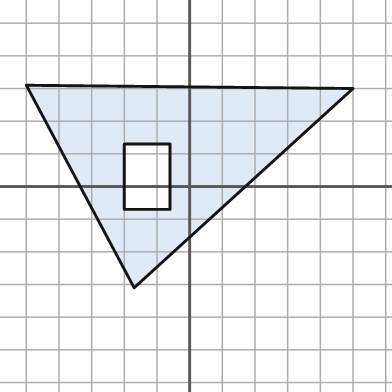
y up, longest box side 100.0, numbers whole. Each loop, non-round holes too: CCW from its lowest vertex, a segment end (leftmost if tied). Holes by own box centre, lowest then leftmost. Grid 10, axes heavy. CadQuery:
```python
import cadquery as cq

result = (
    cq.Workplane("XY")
    .moveTo(-17.0, -31.0)
    .lineTo(50.0, 30.0)
    .lineTo(-50.0, 31.0)
    .close()
    .moveTo(-20.0, -7.0)
    .lineTo(-6.0, -7.0)
    .lineTo(-6.0, 13.0)
    .lineTo(-20.0, 13.0)
    .close()
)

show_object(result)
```